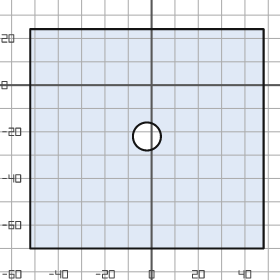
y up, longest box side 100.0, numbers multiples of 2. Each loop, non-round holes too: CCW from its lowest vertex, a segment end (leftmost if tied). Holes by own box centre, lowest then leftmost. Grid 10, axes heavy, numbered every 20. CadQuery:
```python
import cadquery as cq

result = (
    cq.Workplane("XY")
    .moveTo(-52.0, -70.0)
    .lineTo(48.0, -70.0)
    .lineTo(48.0, 24.0)
    .lineTo(-52.0, 24.0)
    .close()
    .moveTo(-2.0, -22.0)
    .circle(6.0)
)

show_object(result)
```